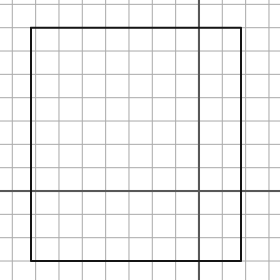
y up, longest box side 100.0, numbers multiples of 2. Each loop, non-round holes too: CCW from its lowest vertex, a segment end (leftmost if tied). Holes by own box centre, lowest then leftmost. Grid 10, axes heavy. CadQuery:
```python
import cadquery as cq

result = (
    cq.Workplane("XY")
    .moveTo(-72.0, -30.0)
    .lineTo(18.0, -30.0)
    .lineTo(18.0, 70.0)
    .lineTo(-72.0, 70.0)
    .close()
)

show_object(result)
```